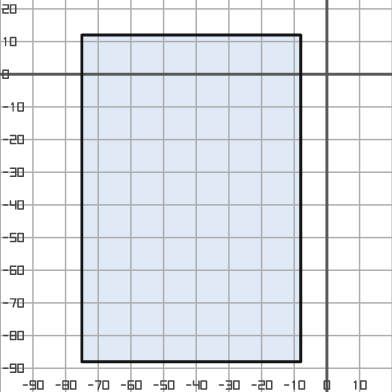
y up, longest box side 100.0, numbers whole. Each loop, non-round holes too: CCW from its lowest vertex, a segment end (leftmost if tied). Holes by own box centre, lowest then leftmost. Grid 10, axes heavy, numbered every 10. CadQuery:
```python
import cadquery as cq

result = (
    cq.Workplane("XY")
    .moveTo(-75.0, -88.0)
    .lineTo(-8.0, -88.0)
    .lineTo(-8.0, 12.0)
    .lineTo(-75.0, 12.0)
    .close()
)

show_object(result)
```